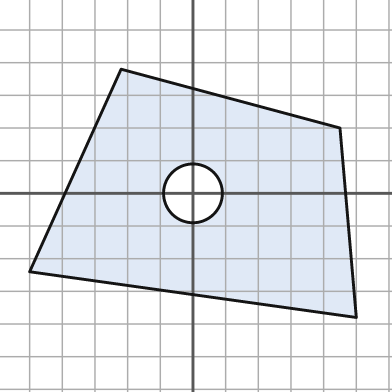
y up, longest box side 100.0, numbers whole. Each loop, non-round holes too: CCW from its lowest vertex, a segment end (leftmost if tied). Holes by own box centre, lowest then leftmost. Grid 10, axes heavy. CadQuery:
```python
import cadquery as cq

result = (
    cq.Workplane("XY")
    .moveTo(50.0, -38.0)
    .lineTo(45.0, 20.0)
    .lineTo(-22.0, 38.0)
    .lineTo(-50.0, -24.0)
    .close()
    .moveTo(0.0, 0.0)
    .circle(9.0)
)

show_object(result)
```